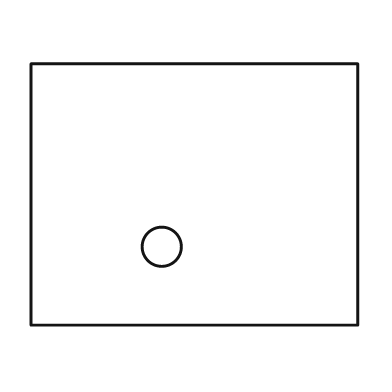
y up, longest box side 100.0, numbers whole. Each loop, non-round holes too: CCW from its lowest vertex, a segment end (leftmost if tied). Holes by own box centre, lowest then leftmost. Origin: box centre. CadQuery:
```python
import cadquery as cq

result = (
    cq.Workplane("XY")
    .moveTo(-50.0, -40.0)
    .lineTo(50.0, -40.0)
    .lineTo(50.0, 40.0)
    .lineTo(-50.0, 40.0)
    .close()
    .moveTo(-10.0, -16.0)
    .circle(6.0)
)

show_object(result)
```